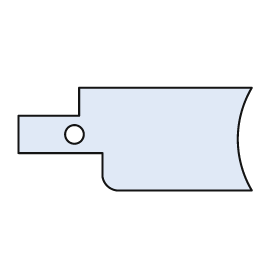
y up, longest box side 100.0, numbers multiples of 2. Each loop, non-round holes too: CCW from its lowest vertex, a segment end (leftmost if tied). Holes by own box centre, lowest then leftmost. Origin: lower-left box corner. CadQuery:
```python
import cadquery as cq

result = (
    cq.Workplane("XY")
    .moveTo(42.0, 0.0)
    .lineTo(100.0, 0.0)
    .threePointArc((94.0, 22.0), (100.0, 44.0))
    .lineTo(26.0, 44.0)
    .lineTo(26.0, 32.0)
    .lineTo(0.0, 32.0)
    .lineTo(0.0, 16.0)
    .lineTo(36.0, 16.0)
    .lineTo(36.0, 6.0)
    .threePointArc((38.0, 2.0), (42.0, 0.0))
    .close()
    .moveTo(24.0, 24.0)
    .circle(4.0)
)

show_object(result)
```